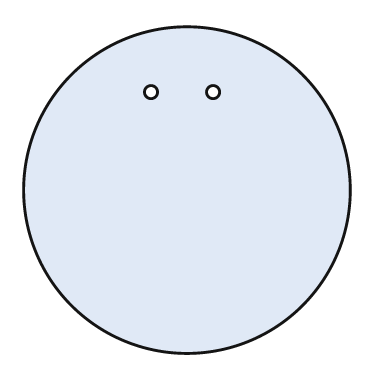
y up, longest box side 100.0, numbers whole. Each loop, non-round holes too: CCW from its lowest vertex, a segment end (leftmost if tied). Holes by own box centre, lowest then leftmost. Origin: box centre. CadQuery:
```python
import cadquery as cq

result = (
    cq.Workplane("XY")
    .moveTo(0.0, 0.0)
    .circle(50.0)
    .moveTo(-11.0, 30.0)
    .circle(2.0)
    .moveTo(8.0, 30.0)
    .circle(2.0)
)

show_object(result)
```